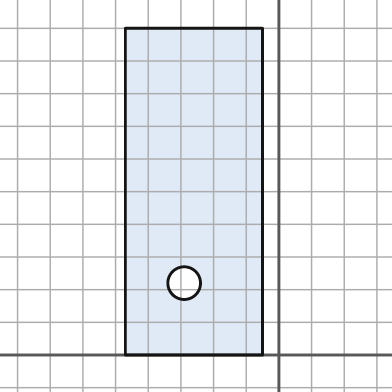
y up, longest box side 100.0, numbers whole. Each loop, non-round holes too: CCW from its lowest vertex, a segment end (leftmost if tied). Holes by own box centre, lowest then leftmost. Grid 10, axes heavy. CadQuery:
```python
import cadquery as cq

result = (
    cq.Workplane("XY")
    .moveTo(-47.0, 0.0)
    .lineTo(-5.0, 0.0)
    .lineTo(-5.0, 100.0)
    .lineTo(-47.0, 100.0)
    .close()
    .moveTo(-29.0, 22.0)
    .circle(5.0)
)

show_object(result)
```